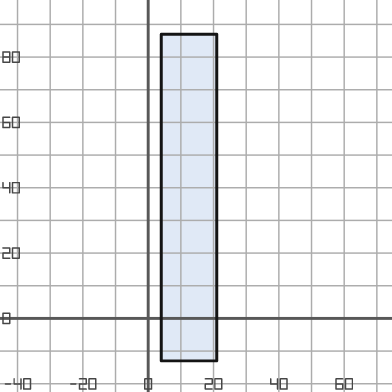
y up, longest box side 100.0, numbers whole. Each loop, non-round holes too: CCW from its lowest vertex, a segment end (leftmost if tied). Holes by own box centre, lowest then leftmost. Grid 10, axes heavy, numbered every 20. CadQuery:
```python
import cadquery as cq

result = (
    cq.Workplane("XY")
    .moveTo(4.0, -13.0)
    .lineTo(21.0, -13.0)
    .lineTo(21.0, 87.0)
    .lineTo(4.0, 87.0)
    .close()
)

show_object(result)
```